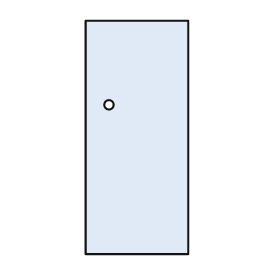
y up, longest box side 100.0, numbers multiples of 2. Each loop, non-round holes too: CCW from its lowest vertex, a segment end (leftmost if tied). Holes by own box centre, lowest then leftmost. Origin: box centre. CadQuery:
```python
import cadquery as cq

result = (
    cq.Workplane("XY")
    .moveTo(-22.0, -50.0)
    .lineTo(22.0, -50.0)
    .lineTo(22.0, 50.0)
    .lineTo(-22.0, 50.0)
    .close()
    .moveTo(-12.0, 14.0)
    .circle(2.0)
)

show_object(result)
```